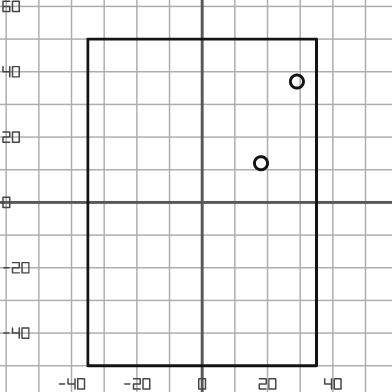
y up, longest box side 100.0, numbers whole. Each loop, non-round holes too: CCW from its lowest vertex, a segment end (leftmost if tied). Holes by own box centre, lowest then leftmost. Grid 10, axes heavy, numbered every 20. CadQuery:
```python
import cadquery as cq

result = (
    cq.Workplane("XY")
    .moveTo(-35.0, -50.0)
    .lineTo(35.0, -50.0)
    .lineTo(35.0, 50.0)
    .lineTo(-35.0, 50.0)
    .close()
    .moveTo(18.0, 12.0)
    .circle(2.0)
    .moveTo(29.0, 37.0)
    .circle(2.0)
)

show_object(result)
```